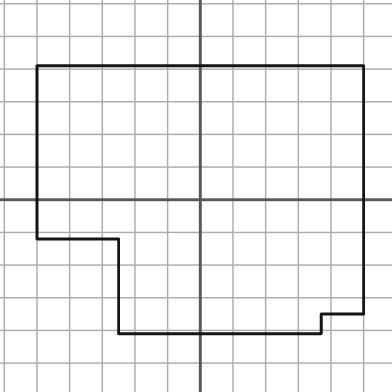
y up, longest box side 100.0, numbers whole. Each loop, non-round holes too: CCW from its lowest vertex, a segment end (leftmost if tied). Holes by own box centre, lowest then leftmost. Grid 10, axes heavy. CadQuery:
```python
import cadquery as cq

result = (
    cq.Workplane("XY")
    .moveTo(-25.0, -41.0)
    .lineTo(37.0, -41.0)
    .lineTo(37.0, -35.0)
    .lineTo(50.0, -35.0)
    .lineTo(50.0, 41.0)
    .lineTo(-50.0, 41.0)
    .lineTo(-50.0, -12.0)
    .lineTo(-25.0, -12.0)
    .close()
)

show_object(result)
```